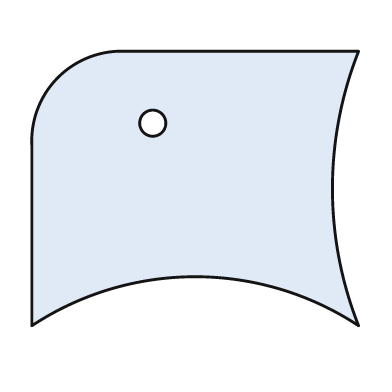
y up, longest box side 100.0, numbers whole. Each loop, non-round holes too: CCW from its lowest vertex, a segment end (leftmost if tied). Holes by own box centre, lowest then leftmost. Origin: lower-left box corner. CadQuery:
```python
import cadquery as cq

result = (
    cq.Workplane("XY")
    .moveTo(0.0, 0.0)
    .threePointArc((50.0, 15.0), (100.0, 0.0))
    .threePointArc((92.0, 42.0), (100.0, 84.0))
    .lineTo(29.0, 84.0)
    .threePointArc((8.0, 76.0), (0.0, 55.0))
    .close()
    .moveTo(37.0, 62.0)
    .circle(4.0)
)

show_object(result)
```